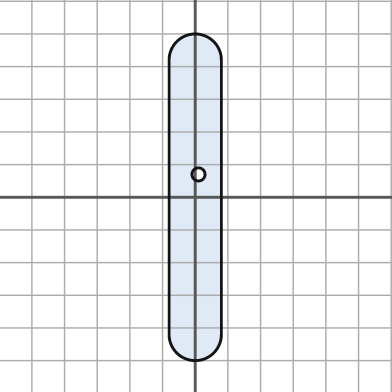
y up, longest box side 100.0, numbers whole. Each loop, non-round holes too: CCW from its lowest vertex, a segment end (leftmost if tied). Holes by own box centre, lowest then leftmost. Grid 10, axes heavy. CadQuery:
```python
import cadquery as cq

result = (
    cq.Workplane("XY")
    .moveTo(-8.0, -42.0)
    .threePointArc((0.0, -50.0), (8.0, -42.0))
    .lineTo(8.0, 42.0)
    .threePointArc((0.0, 50.0), (-8.0, 42.0))
    .close()
    .moveTo(1.0, 7.0)
    .circle(2.0)
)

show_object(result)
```